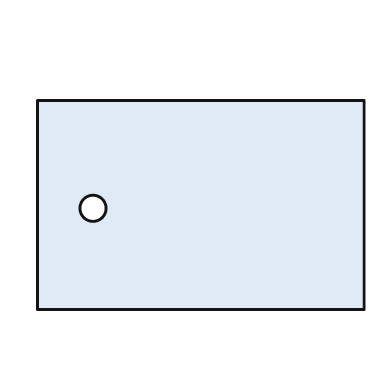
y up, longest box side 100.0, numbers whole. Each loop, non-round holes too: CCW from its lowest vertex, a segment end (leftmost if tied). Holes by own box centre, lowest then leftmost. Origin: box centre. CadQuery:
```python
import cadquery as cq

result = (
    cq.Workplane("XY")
    .moveTo(-50.0, -32.0)
    .lineTo(50.0, -32.0)
    .lineTo(50.0, 32.0)
    .lineTo(-50.0, 32.0)
    .close()
    .moveTo(-33.0, -1.0)
    .circle(4.0)
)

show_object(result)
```